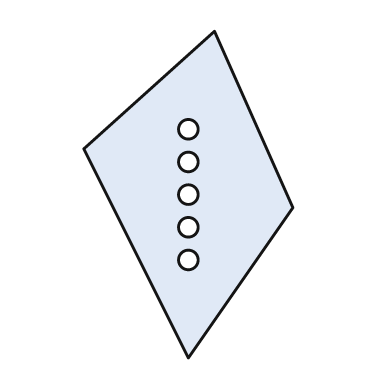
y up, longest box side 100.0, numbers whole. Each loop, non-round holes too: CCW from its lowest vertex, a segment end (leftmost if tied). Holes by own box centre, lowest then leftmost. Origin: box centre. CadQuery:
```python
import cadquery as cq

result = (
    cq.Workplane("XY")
    .moveTo(0.0, -50.0)
    .lineTo(32.0, -4.0)
    .lineTo(8.0, 50.0)
    .lineTo(-32.0, 14.0)
    .close()
    .moveTo(0.0, -20.0)
    .circle(3.0)
    .moveTo(0.0, -10.0)
    .circle(3.0)
    .moveTo(0.0, 0.0)
    .circle(3.0)
    .moveTo(0.0, 10.0)
    .circle(3.0)
    .moveTo(0.0, 20.0)
    .circle(3.0)
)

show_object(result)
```